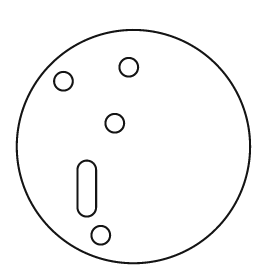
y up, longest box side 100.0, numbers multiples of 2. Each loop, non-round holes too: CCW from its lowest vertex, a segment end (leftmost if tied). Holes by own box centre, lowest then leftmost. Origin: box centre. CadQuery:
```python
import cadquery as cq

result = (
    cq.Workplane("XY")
    .moveTo(0.0, 0.0)
    .circle(50.0)
    .moveTo(-14.0, -38.0)
    .circle(4.0)
    .moveTo(-24.0, -26.0)
    .threePointArc((-20.0, -30.0), (-16.0, -26.0))
    .lineTo(-16.0, -10.0)
    .threePointArc((-20.0, -6.0), (-24.0, -10.0))
    .close()
    .moveTo(-8.0, 10.0)
    .circle(4.0)
    .moveTo(-30.0, 28.0)
    .circle(4.0)
    .moveTo(-2.0, 34.0)
    .circle(4.0)
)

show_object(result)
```